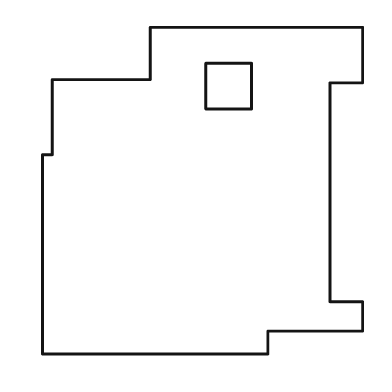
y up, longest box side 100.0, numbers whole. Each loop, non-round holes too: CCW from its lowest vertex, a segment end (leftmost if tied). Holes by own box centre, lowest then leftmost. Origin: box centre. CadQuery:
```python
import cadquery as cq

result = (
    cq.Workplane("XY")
    .moveTo(-49.0, -50.0)
    .lineTo(20.0, -50.0)
    .lineTo(20.0, -43.0)
    .lineTo(49.0, -43.0)
    .lineTo(49.0, -34.0)
    .lineTo(39.0, -34.0)
    .lineTo(39.0, 33.0)
    .lineTo(49.0, 33.0)
    .lineTo(49.0, 50.0)
    .lineTo(-16.0, 50.0)
    .lineTo(-16.0, 34.0)
    .lineTo(-46.0, 34.0)
    .lineTo(-46.0, 11.0)
    .lineTo(-49.0, 11.0)
    .close()
    .moveTo(1.0, 25.0)
    .lineTo(15.0, 25.0)
    .lineTo(15.0, 39.0)
    .lineTo(1.0, 39.0)
    .close()
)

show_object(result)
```